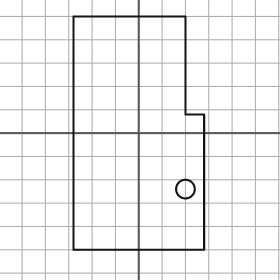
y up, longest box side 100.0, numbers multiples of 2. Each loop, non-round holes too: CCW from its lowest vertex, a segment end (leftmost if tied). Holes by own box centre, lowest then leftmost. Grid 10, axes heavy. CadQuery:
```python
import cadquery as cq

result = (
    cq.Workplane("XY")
    .moveTo(-28.0, -50.0)
    .lineTo(28.0, -50.0)
    .lineTo(28.0, 8.0)
    .lineTo(20.0, 8.0)
    .lineTo(20.0, 50.0)
    .lineTo(-28.0, 50.0)
    .close()
    .moveTo(20.0, -24.0)
    .circle(4.0)
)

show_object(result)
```